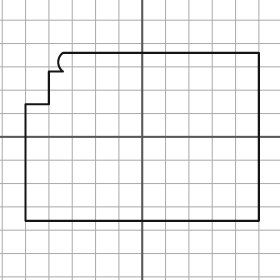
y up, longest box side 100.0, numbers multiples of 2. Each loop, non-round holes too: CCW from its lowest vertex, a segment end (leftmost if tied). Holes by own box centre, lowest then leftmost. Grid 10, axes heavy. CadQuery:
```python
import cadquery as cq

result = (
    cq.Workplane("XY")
    .moveTo(-50.0, -36.0)
    .lineTo(50.0, -36.0)
    .lineTo(50.0, 36.0)
    .lineTo(-34.0, 36.0)
    .threePointArc((-36.0, 32.0), (-34.0, 28.0))
    .lineTo(-40.0, 28.0)
    .lineTo(-40.0, 14.0)
    .lineTo(-50.0, 14.0)
    .close()
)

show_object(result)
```